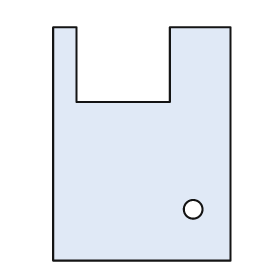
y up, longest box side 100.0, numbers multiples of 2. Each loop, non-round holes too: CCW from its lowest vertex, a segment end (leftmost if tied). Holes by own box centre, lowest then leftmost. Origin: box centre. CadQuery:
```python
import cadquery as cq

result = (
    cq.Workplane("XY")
    .moveTo(-38.0, -50.0)
    .lineTo(38.0, -50.0)
    .lineTo(38.0, 50.0)
    .lineTo(12.0, 50.0)
    .lineTo(12.0, 18.0)
    .lineTo(-28.0, 18.0)
    .lineTo(-28.0, 50.0)
    .lineTo(-38.0, 50.0)
    .close()
    .moveTo(22.0, -28.0)
    .circle(4.0)
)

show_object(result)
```